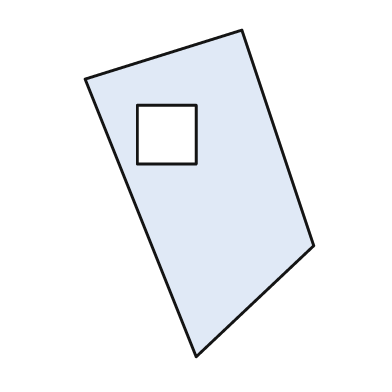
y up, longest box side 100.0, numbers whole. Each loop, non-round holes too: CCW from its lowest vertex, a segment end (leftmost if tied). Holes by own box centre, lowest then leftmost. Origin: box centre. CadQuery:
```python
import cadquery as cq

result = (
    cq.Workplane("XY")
    .moveTo(-1.0, -50.0)
    .lineTo(35.0, -16.0)
    .lineTo(13.0, 50.0)
    .lineTo(-35.0, 35.0)
    .close()
    .moveTo(-19.0, 9.0)
    .lineTo(-1.0, 9.0)
    .lineTo(-1.0, 27.0)
    .lineTo(-19.0, 27.0)
    .close()
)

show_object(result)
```